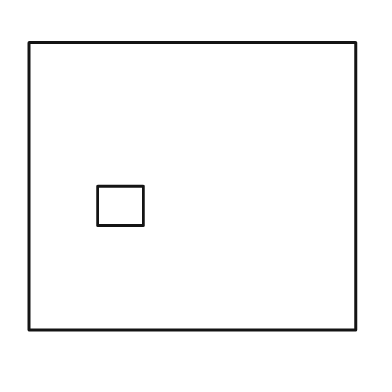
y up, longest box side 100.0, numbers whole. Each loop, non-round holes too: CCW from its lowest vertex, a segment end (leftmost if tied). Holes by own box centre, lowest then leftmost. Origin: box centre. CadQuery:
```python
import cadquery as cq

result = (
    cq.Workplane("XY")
    .moveTo(-50.0, -44.0)
    .lineTo(50.0, -44.0)
    .lineTo(50.0, 44.0)
    .lineTo(-50.0, 44.0)
    .close()
    .moveTo(-29.0, -12.0)
    .lineTo(-15.0, -12.0)
    .lineTo(-15.0, 0.0)
    .lineTo(-29.0, 0.0)
    .close()
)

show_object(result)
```